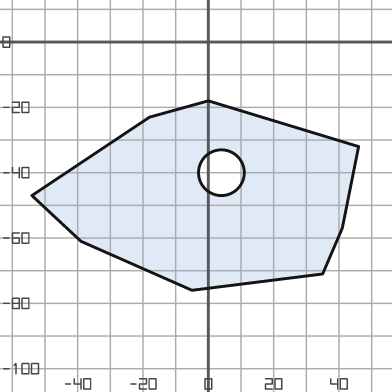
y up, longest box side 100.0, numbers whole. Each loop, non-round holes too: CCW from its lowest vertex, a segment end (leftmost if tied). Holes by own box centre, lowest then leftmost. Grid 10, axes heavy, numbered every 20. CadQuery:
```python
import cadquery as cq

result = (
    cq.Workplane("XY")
    .moveTo(-5.0, -76.0)
    .lineTo(35.0, -71.0)
    .lineTo(41.0, -57.0)
    .lineTo(46.0, -32.0)
    .lineTo(0.0, -18.0)
    .lineTo(-18.0, -23.0)
    .lineTo(-54.0, -47.0)
    .lineTo(-39.0, -61.0)
    .close()
    .moveTo(4.0, -40.0)
    .circle(7.0)
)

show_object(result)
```